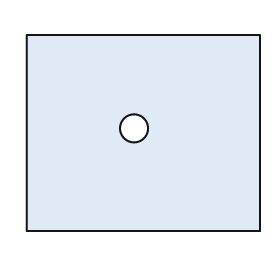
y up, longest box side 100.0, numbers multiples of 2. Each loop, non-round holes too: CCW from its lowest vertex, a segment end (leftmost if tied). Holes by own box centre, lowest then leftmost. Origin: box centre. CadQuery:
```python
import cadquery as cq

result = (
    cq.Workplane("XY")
    .moveTo(-50.0, -42.0)
    .lineTo(50.0, -42.0)
    .lineTo(50.0, 42.0)
    .lineTo(-50.0, 42.0)
    .close()
    .moveTo(-4.0, 2.0)
    .circle(6.0)
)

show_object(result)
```